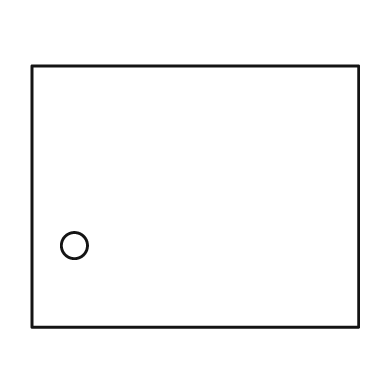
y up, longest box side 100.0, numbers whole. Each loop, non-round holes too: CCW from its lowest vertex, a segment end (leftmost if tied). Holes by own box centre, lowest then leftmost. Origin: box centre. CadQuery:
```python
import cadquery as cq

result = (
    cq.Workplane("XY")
    .moveTo(-50.0, -40.0)
    .lineTo(50.0, -40.0)
    .lineTo(50.0, 40.0)
    .lineTo(-50.0, 40.0)
    .close()
    .moveTo(-37.0, -15.0)
    .circle(4.0)
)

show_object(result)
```